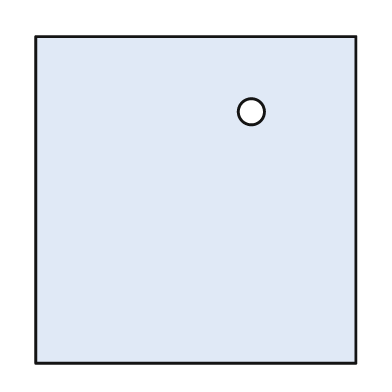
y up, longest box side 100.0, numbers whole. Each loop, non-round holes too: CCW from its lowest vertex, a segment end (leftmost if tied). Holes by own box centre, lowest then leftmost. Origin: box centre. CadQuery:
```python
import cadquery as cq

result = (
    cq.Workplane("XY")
    .moveTo(-49.0, -50.0)
    .lineTo(49.0, -50.0)
    .lineTo(49.0, 50.0)
    .lineTo(-49.0, 50.0)
    .close()
    .moveTo(17.0, 27.0)
    .circle(4.0)
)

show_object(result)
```